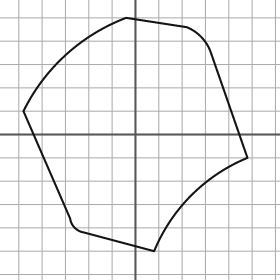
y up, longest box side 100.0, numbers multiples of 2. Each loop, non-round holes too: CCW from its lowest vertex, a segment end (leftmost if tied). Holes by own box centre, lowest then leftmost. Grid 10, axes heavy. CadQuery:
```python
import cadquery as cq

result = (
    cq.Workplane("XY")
    .moveTo(8.0, -50.0)
    .threePointArc((24.0, -26.0), (48.0, -10.0))
    .lineTo(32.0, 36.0)
    .threePointArc((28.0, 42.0), (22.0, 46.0))
    .lineTo(-4.0, 50.0)
    .threePointArc((-30.0, 34.0), (-48.0, 10.0))
    .lineTo(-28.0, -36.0)
    .threePointArc((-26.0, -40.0), (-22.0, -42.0))
    .close()
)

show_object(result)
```